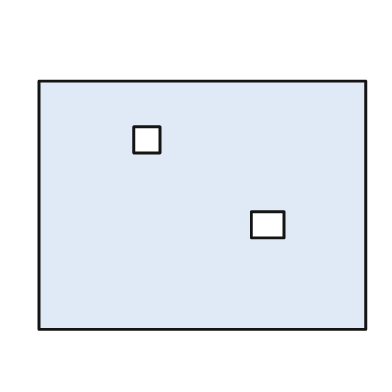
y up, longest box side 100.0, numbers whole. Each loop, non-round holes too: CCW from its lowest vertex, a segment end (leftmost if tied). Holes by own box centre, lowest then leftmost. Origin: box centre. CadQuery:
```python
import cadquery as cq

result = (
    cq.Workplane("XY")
    .moveTo(-50.0, -38.0)
    .lineTo(50.0, -38.0)
    .lineTo(50.0, 38.0)
    .lineTo(-50.0, 38.0)
    .close()
    .moveTo(15.0, -10.0)
    .lineTo(25.0, -10.0)
    .lineTo(25.0, -2.0)
    .lineTo(15.0, -2.0)
    .close()
    .moveTo(-21.0, 16.0)
    .lineTo(-13.0, 16.0)
    .lineTo(-13.0, 24.0)
    .lineTo(-21.0, 24.0)
    .close()
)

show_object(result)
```